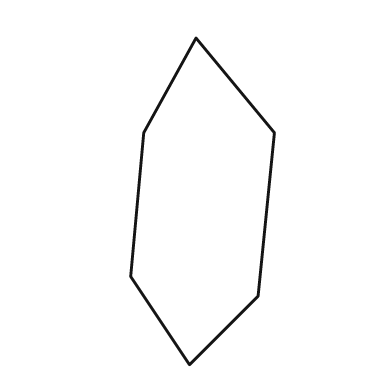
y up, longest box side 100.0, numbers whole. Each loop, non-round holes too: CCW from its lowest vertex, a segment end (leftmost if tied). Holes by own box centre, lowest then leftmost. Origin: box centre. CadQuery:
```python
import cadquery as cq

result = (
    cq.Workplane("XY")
    .moveTo(-4.0, -50.0)
    .lineTo(17.0, -29.0)
    .lineTo(22.0, 21.0)
    .lineTo(-2.0, 50.0)
    .lineTo(-18.0, 21.0)
    .lineTo(-22.0, -23.0)
    .close()
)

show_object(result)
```